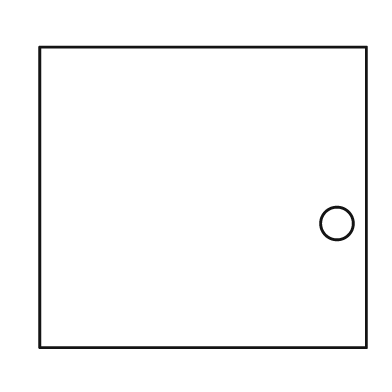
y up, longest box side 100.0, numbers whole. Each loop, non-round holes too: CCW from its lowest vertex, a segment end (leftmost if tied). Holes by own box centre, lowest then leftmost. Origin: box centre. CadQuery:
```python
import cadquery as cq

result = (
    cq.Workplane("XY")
    .moveTo(-50.0, -46.0)
    .lineTo(50.0, -46.0)
    .lineTo(50.0, 46.0)
    .lineTo(-50.0, 46.0)
    .close()
    .moveTo(41.0, -8.0)
    .circle(5.0)
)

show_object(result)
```